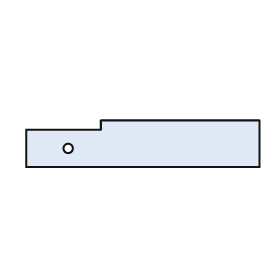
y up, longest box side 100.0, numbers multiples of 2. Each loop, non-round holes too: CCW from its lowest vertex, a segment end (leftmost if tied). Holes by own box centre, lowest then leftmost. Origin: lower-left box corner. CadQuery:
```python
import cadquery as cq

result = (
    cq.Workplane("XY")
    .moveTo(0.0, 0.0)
    .lineTo(100.0, 0.0)
    .lineTo(100.0, 20.0)
    .lineTo(32.0, 20.0)
    .lineTo(32.0, 16.0)
    .lineTo(0.0, 16.0)
    .close()
    .moveTo(18.0, 8.0)
    .circle(2.0)
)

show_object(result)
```